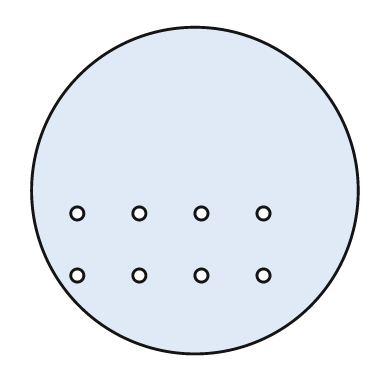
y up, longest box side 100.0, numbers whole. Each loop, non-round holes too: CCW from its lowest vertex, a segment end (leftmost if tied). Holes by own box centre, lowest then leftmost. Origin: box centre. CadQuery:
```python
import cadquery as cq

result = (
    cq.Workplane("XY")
    .moveTo(0.0, 0.0)
    .circle(50.0)
    .moveTo(-36.0, -26.0)
    .circle(2.0)
    .moveTo(-17.0, -26.0)
    .circle(2.0)
    .moveTo(2.0, -26.0)
    .circle(2.0)
    .moveTo(21.0, -26.0)
    .circle(2.0)
    .moveTo(-36.0, -7.0)
    .circle(2.0)
    .moveTo(-17.0, -7.0)
    .circle(2.0)
    .moveTo(2.0, -7.0)
    .circle(2.0)
    .moveTo(21.0, -7.0)
    .circle(2.0)
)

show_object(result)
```